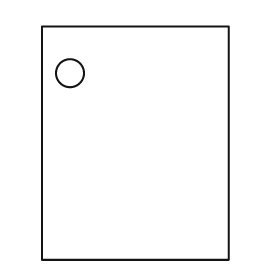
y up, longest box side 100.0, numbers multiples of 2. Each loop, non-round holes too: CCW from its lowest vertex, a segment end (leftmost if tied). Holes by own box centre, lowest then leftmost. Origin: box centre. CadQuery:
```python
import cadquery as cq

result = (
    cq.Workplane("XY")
    .moveTo(-40.0, -50.0)
    .lineTo(40.0, -50.0)
    .lineTo(40.0, 50.0)
    .lineTo(-40.0, 50.0)
    .close()
    .moveTo(-28.0, 30.0)
    .circle(6.0)
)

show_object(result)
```